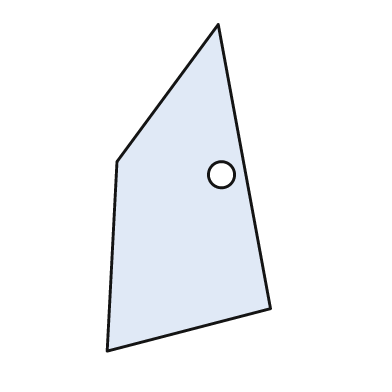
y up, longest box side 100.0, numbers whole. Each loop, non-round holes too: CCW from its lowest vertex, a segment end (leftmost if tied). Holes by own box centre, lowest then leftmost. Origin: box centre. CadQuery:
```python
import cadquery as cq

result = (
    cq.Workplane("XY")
    .moveTo(-25.0, -50.0)
    .lineTo(25.0, -37.0)
    .lineTo(9.0, 50.0)
    .lineTo(-22.0, 8.0)
    .close()
    .moveTo(10.0, 4.0)
    .circle(4.0)
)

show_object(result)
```